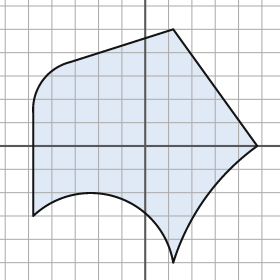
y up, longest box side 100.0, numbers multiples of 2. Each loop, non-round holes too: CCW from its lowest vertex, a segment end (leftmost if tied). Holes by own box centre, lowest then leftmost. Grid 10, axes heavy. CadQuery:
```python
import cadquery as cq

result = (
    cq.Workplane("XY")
    .moveTo(12.0, -50.0)
    .threePointArc((26.0, -22.0), (48.0, 0.0))
    .lineTo(12.0, 50.0)
    .lineTo(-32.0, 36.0)
    .threePointArc((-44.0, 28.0), (-48.0, 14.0))
    .lineTo(-48.0, -30.0)
    .threePointArc((-12.0, -22.0), (12.0, -50.0))
    .close()
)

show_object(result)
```